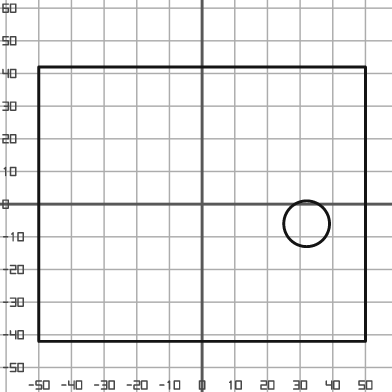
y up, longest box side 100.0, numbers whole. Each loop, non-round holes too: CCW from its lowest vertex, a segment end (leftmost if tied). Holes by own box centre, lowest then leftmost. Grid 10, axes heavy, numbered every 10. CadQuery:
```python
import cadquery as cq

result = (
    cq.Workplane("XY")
    .moveTo(-50.0, -42.0)
    .lineTo(50.0, -42.0)
    .lineTo(50.0, 42.0)
    .lineTo(-50.0, 42.0)
    .close()
    .moveTo(32.0, -6.0)
    .circle(7.0)
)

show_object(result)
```